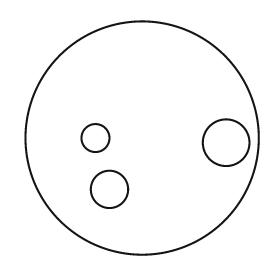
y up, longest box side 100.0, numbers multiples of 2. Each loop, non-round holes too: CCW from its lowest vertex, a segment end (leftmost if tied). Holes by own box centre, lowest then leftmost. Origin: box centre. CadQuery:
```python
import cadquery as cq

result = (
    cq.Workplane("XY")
    .moveTo(0.0, 0.0)
    .circle(50.0)
    .moveTo(-14.0, -22.0)
    .circle(8.0)
    .moveTo(36.0, -2.0)
    .circle(10.0)
    .moveTo(-20.0, 0.0)
    .circle(6.0)
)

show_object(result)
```